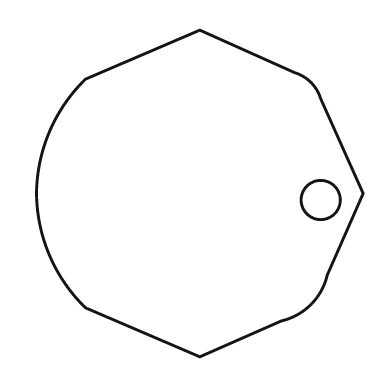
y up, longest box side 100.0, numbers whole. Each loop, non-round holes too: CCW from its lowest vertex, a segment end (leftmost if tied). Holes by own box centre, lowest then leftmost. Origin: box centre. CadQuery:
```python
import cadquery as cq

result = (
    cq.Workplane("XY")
    .moveTo(0.0, -50.0)
    .lineTo(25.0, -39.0)
    .threePointArc((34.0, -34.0), (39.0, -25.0))
    .lineTo(50.0, 0.0)
    .lineTo(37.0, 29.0)
    .threePointArc((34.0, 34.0), (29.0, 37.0))
    .lineTo(0.0, 50.0)
    .lineTo(-35.0, 35.0)
    .threePointArc((-46.0, 19.0), (-50.0, 0.0))
    .threePointArc((-46.0, -19.0), (-35.0, -35.0))
    .close()
    .moveTo(37.0, -2.0)
    .circle(6.0)
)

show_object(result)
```